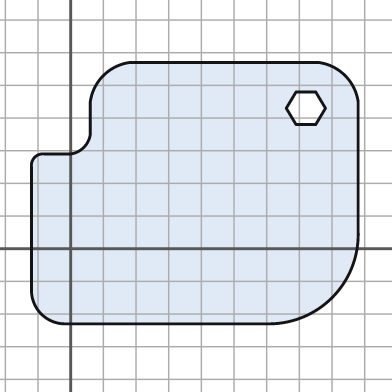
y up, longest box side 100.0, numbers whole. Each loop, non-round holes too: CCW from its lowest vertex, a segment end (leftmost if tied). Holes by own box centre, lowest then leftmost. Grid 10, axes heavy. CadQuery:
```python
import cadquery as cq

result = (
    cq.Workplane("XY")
    .moveTo(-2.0, -23.0)
    .lineTo(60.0, -23.0)
    .threePointArc((80.0, -15.0), (88.0, 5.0))
    .lineTo(88.0, 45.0)
    .threePointArc((84.0, 53.0), (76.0, 57.0))
    .lineTo(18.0, 57.0)
    .threePointArc((10.0, 53.0), (6.0, 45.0))
    .lineTo(6.0, 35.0)
    .threePointArc((4.0, 31.0), (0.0, 29.0))
    .lineTo(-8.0, 29.0)
    .threePointArc((-11.0, 28.0), (-12.0, 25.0))
    .lineTo(-12.0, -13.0)
    .threePointArc((-9.0, -20.0), (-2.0, -23.0))
    .close()
    .moveTo(69.0, 38.0)
    .lineTo(75.0, 38.0)
    .lineTo(78.0, 43.0)
    .lineTo(75.0, 48.0)
    .lineTo(69.0, 48.0)
    .lineTo(66.0, 43.0)
    .close()
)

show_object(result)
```